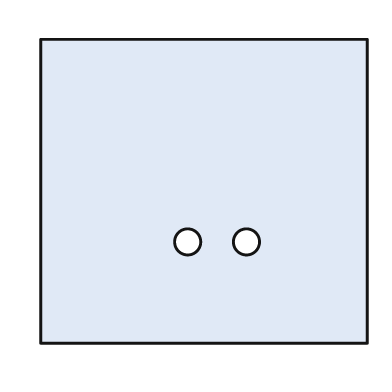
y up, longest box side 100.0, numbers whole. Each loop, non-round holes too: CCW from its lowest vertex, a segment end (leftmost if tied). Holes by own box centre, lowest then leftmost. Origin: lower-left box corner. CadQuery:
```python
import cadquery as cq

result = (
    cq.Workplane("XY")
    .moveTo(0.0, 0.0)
    .lineTo(100.0, 0.0)
    .lineTo(100.0, 93.0)
    .lineTo(0.0, 93.0)
    .close()
    .moveTo(45.0, 31.0)
    .circle(4.0)
    .moveTo(63.0, 31.0)
    .circle(4.0)
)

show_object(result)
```